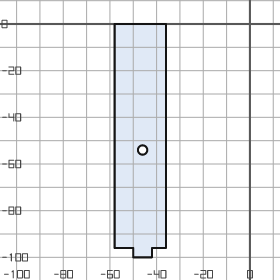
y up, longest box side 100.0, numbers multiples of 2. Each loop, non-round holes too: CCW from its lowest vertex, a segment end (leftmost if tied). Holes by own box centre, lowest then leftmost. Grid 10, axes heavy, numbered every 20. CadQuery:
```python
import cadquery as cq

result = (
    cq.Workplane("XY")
    .moveTo(-50.0, -100.0)
    .lineTo(-42.0, -100.0)
    .lineTo(-42.0, -96.0)
    .lineTo(-36.0, -96.0)
    .lineTo(-36.0, 0.0)
    .lineTo(-58.0, 0.0)
    .lineTo(-58.0, -96.0)
    .lineTo(-50.0, -96.0)
    .close()
    .moveTo(-46.0, -54.0)
    .circle(2.0)
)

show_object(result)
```